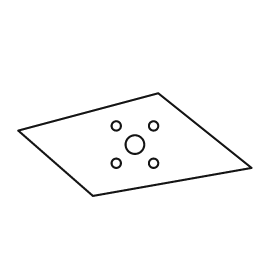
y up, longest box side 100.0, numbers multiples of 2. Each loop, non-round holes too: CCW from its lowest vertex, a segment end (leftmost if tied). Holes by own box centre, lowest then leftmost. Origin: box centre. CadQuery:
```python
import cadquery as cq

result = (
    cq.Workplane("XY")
    .moveTo(-18.0, -22.0)
    .lineTo(50.0, -10.0)
    .lineTo(10.0, 22.0)
    .lineTo(-50.0, 6.0)
    .close()
    .moveTo(-8.0, -8.0)
    .circle(2.0)
    .moveTo(8.0, -8.0)
    .circle(2.0)
    .moveTo(0.0, 0.0)
    .circle(4.0)
    .moveTo(-8.0, 8.0)
    .circle(2.0)
    .moveTo(8.0, 8.0)
    .circle(2.0)
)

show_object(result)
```